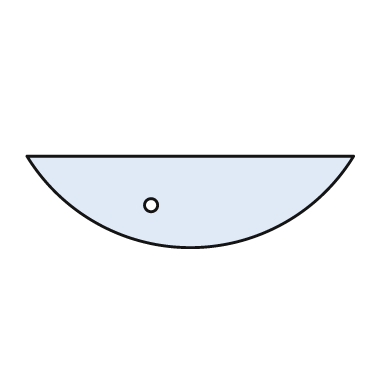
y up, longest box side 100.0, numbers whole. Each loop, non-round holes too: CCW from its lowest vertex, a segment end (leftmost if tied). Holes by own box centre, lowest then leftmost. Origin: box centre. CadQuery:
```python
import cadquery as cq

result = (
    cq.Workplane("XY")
    .moveTo(-50.0, 14.0)
    .threePointArc((0.0, -14.0), (50.0, 14.0))
    .close()
    .moveTo(-12.0, -1.0)
    .circle(2.0)
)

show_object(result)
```